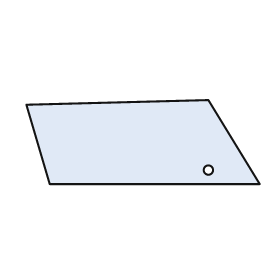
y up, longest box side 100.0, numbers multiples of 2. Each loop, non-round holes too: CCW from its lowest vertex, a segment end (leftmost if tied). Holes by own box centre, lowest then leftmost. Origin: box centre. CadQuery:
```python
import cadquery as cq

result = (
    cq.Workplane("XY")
    .moveTo(-40.0, -18.0)
    .lineTo(50.0, -18.0)
    .lineTo(28.0, 18.0)
    .lineTo(-50.0, 16.0)
    .close()
    .moveTo(28.0, -12.0)
    .circle(2.0)
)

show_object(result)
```